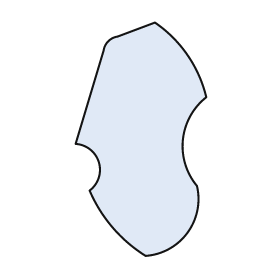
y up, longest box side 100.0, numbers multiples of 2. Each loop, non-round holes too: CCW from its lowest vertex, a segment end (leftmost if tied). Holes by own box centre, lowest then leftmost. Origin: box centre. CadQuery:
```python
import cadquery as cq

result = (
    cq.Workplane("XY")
    .moveTo(2.0, -50.0)
    .threePointArc((20.0, -40.0), (24.0, -20.0))
    .threePointArc((18.0, 0.0), (28.0, 18.0))
    .threePointArc((20.0, 36.0), (6.0, 50.0))
    .lineTo(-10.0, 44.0)
    .threePointArc((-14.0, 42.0), (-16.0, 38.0))
    .lineTo(-28.0, -2.0)
    .threePointArc((-18.0, -10.0), (-22.0, -22.0))
    .threePointArc((-12.0, -38.0), (2.0, -50.0))
    .close()
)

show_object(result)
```